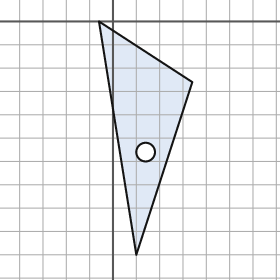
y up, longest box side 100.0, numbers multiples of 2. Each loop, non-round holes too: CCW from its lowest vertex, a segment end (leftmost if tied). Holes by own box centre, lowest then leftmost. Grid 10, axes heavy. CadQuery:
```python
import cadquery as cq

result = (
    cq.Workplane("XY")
    .moveTo(10.0, -100.0)
    .lineTo(34.0, -26.0)
    .lineTo(-6.0, 0.0)
    .close()
    .moveTo(14.0, -56.0)
    .circle(4.0)
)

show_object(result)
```